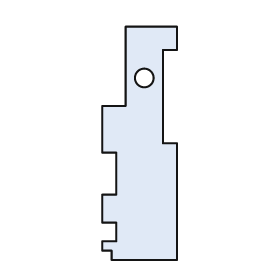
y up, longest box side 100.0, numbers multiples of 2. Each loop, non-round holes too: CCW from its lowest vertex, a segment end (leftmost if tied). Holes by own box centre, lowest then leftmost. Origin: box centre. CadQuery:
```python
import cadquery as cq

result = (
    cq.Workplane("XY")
    .moveTo(-12.0, -50.0)
    .lineTo(16.0, -50.0)
    .lineTo(16.0, 0.0)
    .lineTo(10.0, 0.0)
    .lineTo(10.0, 40.0)
    .lineTo(16.0, 40.0)
    .lineTo(16.0, 50.0)
    .lineTo(-6.0, 50.0)
    .lineTo(-6.0, 16.0)
    .lineTo(-16.0, 16.0)
    .lineTo(-16.0, -4.0)
    .lineTo(-10.0, -4.0)
    .lineTo(-10.0, -22.0)
    .lineTo(-16.0, -22.0)
    .lineTo(-16.0, -34.0)
    .lineTo(-10.0, -34.0)
    .lineTo(-10.0, -42.0)
    .lineTo(-16.0, -42.0)
    .lineTo(-16.0, -46.0)
    .lineTo(-12.0, -46.0)
    .close()
    .moveTo(2.0, 28.0)
    .circle(4.0)
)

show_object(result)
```